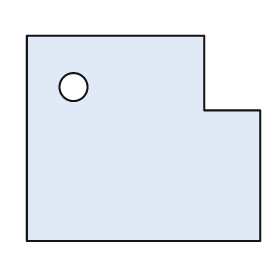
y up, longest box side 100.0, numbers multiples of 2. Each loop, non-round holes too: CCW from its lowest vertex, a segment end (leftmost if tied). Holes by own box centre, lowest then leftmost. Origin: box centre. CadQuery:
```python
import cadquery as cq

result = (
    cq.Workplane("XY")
    .moveTo(-50.0, -44.0)
    .lineTo(50.0, -44.0)
    .lineTo(50.0, 12.0)
    .lineTo(26.0, 12.0)
    .lineTo(26.0, 44.0)
    .lineTo(-50.0, 44.0)
    .close()
    .moveTo(-30.0, 22.0)
    .circle(6.0)
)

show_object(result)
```